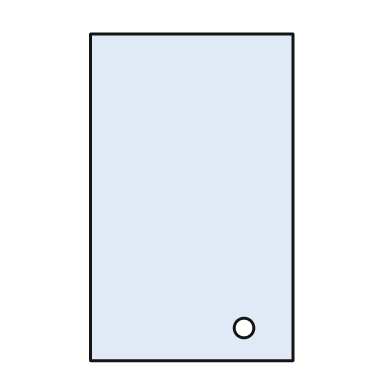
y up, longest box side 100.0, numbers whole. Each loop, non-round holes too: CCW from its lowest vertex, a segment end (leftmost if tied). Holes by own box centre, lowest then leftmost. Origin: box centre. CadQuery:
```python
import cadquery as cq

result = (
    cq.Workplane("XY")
    .moveTo(-31.0, -50.0)
    .lineTo(31.0, -50.0)
    .lineTo(31.0, 50.0)
    .lineTo(-31.0, 50.0)
    .close()
    .moveTo(16.0, -40.0)
    .circle(3.0)
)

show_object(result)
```